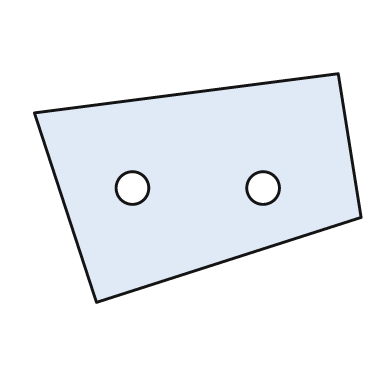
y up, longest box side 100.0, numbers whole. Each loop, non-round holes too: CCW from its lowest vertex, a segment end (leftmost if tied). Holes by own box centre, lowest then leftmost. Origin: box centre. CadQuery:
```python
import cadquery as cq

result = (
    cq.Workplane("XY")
    .moveTo(-31.0, -35.0)
    .lineTo(50.0, -9.0)
    .lineTo(43.0, 35.0)
    .lineTo(-50.0, 23.0)
    .close()
    .moveTo(-20.0, 0.0)
    .circle(5.0)
    .moveTo(20.0, 0.0)
    .circle(5.0)
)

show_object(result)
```